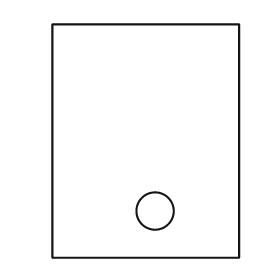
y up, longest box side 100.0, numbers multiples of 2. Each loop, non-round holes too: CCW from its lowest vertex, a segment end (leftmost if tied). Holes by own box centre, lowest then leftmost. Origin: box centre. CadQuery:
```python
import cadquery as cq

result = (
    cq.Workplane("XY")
    .moveTo(-40.0, -50.0)
    .lineTo(40.0, -50.0)
    .lineTo(40.0, 50.0)
    .lineTo(-40.0, 50.0)
    .close()
    .moveTo(4.0, -30.0)
    .circle(8.0)
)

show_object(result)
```